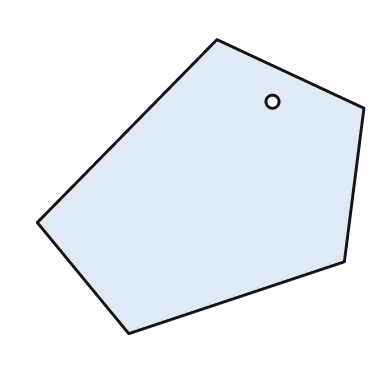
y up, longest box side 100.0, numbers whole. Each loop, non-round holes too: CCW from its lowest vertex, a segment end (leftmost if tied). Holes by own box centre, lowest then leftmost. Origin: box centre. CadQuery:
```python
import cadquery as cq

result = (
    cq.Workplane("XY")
    .moveTo(-22.0, -45.0)
    .lineTo(44.0, -23.0)
    .lineTo(50.0, 24.0)
    .lineTo(5.0, 45.0)
    .lineTo(-50.0, -11.0)
    .close()
    .moveTo(22.0, 26.0)
    .circle(2.0)
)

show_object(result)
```